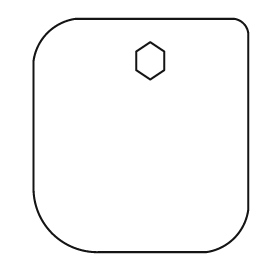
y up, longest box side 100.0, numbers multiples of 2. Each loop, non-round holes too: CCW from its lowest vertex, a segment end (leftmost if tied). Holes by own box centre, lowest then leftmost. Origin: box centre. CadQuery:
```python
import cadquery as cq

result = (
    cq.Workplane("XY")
    .moveTo(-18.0, -50.0)
    .lineTo(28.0, -50.0)
    .threePointArc((40.0, -44.0), (46.0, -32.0))
    .lineTo(46.0, 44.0)
    .threePointArc((44.0, 48.0), (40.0, 50.0))
    .lineTo(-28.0, 50.0)
    .threePointArc((-40.0, 44.0), (-46.0, 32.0))
    .lineTo(-46.0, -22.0)
    .threePointArc((-38.0, -42.0), (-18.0, -50.0))
    .close()
    .moveTo(4.0, 24.0)
    .lineTo(10.0, 28.0)
    .lineTo(10.0, 36.0)
    .lineTo(4.0, 40.0)
    .lineTo(-2.0, 36.0)
    .lineTo(-2.0, 28.0)
    .close()
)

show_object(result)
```